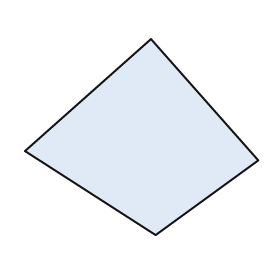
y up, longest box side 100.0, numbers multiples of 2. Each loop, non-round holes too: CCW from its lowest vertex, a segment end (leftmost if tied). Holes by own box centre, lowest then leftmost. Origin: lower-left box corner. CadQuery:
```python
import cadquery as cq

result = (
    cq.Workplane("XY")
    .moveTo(56.0, 0.0)
    .lineTo(100.0, 32.0)
    .lineTo(54.0, 84.0)
    .lineTo(0.0, 36.0)
    .close()
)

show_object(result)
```